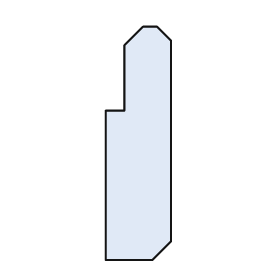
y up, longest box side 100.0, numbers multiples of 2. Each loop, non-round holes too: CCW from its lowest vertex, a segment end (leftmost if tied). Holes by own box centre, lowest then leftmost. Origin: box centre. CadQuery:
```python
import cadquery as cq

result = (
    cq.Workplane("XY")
    .moveTo(-14.0, -50.0)
    .lineTo(6.0, -50.0)
    .lineTo(14.0, -42.0)
    .lineTo(14.0, 44.0)
    .lineTo(8.0, 50.0)
    .lineTo(2.0, 50.0)
    .lineTo(-6.0, 42.0)
    .lineTo(-6.0, 14.0)
    .lineTo(-14.0, 14.0)
    .close()
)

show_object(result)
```